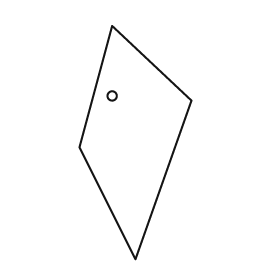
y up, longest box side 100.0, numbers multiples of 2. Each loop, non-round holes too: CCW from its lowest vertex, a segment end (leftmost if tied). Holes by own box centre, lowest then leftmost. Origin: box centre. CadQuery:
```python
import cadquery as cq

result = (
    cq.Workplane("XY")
    .moveTo(0.0, -50.0)
    .lineTo(24.0, 18.0)
    .lineTo(-10.0, 50.0)
    .lineTo(-24.0, -2.0)
    .close()
    .moveTo(-10.0, 20.0)
    .circle(2.0)
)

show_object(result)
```